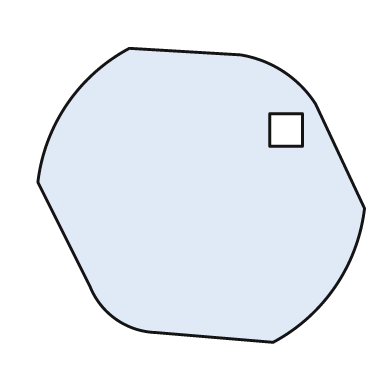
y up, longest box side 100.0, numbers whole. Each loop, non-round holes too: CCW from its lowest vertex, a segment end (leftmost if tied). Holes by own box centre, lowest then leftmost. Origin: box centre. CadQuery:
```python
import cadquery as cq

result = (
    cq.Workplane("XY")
    .moveTo(22.0, -45.0)
    .threePointArc((41.0, -28.0), (50.0, -4.0))
    .lineTo(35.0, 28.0)
    .threePointArc((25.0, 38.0), (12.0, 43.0))
    .lineTo(-22.0, 45.0)
    .threePointArc((-41.0, 28.0), (-50.0, 4.0))
    .lineTo(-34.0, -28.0)
    .threePointArc((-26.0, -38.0), (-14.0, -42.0))
    .close()
    .moveTo(21.0, 15.0)
    .lineTo(31.0, 15.0)
    .lineTo(31.0, 25.0)
    .lineTo(21.0, 25.0)
    .close()
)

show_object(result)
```